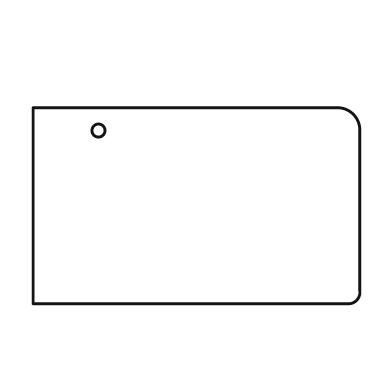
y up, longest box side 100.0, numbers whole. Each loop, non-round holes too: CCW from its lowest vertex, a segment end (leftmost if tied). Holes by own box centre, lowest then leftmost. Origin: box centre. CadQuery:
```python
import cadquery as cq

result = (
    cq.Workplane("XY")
    .moveTo(-50.0, -30.0)
    .lineTo(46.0, -30.0)
    .threePointArc((49.0, -29.0), (50.0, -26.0))
    .lineTo(50.0, 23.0)
    .threePointArc((48.0, 28.0), (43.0, 30.0))
    .lineTo(-50.0, 30.0)
    .close()
    .moveTo(-30.0, 23.0)
    .circle(2.0)
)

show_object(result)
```